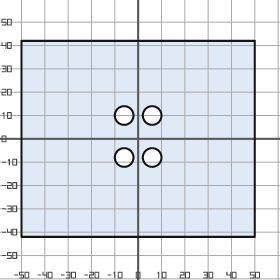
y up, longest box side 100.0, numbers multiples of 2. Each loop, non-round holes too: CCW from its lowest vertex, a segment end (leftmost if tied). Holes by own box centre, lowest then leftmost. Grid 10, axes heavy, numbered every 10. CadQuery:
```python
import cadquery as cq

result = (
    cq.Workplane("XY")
    .moveTo(-50.0, -42.0)
    .lineTo(50.0, -42.0)
    .lineTo(50.0, 42.0)
    .lineTo(-50.0, 42.0)
    .close()
    .moveTo(-6.0, -8.0)
    .circle(4.0)
    .moveTo(6.0, -8.0)
    .circle(4.0)
    .moveTo(-6.0, 10.0)
    .circle(4.0)
    .moveTo(6.0, 10.0)
    .circle(4.0)
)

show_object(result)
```